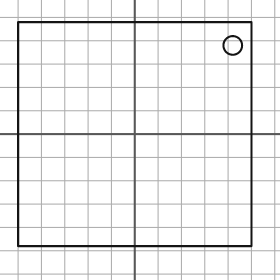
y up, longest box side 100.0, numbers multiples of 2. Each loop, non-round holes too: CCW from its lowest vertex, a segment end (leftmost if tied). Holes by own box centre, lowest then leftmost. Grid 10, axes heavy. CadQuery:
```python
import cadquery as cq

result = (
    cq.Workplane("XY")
    .moveTo(-50.0, -48.0)
    .lineTo(50.0, -48.0)
    .lineTo(50.0, 48.0)
    .lineTo(-50.0, 48.0)
    .close()
    .moveTo(42.0, 38.0)
    .circle(4.0)
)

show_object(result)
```